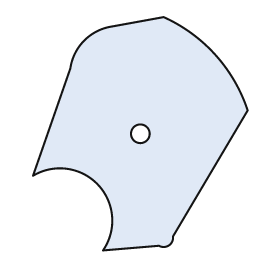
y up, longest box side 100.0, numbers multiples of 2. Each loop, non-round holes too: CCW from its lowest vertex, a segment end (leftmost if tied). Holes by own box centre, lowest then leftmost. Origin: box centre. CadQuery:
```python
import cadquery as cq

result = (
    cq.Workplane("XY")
    .moveTo(-16.0, -50.0)
    .lineTo(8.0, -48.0)
    .threePointArc((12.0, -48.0), (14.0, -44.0))
    .lineTo(46.0, 10.0)
    .threePointArc((32.0, 34.0), (10.0, 50.0))
    .lineTo(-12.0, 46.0)
    .threePointArc((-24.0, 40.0), (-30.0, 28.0))
    .lineTo(-46.0, -18.0)
    .threePointArc((-18.0, -22.0), (-16.0, -50.0))
    .close()
    .moveTo(0.0, 0.0)
    .circle(4.0)
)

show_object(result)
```